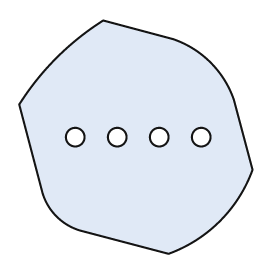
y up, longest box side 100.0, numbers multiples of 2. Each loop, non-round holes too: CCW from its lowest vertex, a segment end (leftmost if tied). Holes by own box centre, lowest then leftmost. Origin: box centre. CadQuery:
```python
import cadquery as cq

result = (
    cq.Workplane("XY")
    .moveTo(14.0, -50.0)
    .threePointArc((36.0, -36.0), (50.0, -14.0))
    .lineTo(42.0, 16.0)
    .threePointArc((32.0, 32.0), (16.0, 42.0))
    .lineTo(-14.0, 50.0)
    .threePointArc((-34.0, 34.0), (-50.0, 14.0))
    .lineTo(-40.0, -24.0)
    .threePointArc((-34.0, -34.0), (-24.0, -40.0))
    .close()
    .moveTo(-26.0, 0.0)
    .circle(4.0)
    .moveTo(-8.0, 0.0)
    .circle(4.0)
    .moveTo(10.0, 0.0)
    .circle(4.0)
    .moveTo(28.0, 0.0)
    .circle(4.0)
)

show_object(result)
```